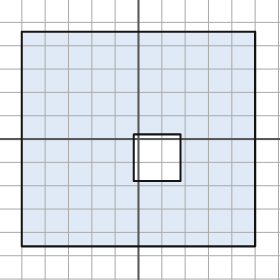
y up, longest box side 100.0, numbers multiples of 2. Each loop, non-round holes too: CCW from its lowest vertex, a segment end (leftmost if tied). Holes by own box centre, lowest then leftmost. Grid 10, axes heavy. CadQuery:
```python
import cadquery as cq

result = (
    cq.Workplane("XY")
    .moveTo(-50.0, -46.0)
    .lineTo(50.0, -46.0)
    .lineTo(50.0, 46.0)
    .lineTo(-50.0, 46.0)
    .close()
    .moveTo(-2.0, -18.0)
    .lineTo(18.0, -18.0)
    .lineTo(18.0, 2.0)
    .lineTo(-2.0, 2.0)
    .close()
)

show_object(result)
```